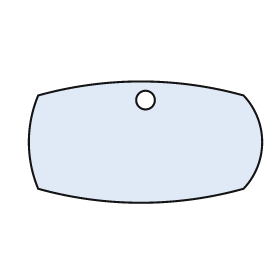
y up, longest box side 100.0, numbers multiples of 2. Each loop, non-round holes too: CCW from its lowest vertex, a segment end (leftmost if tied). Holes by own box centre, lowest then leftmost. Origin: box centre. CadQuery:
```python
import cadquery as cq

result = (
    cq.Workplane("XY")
    .moveTo(-46.0, -20.0)
    .threePointArc((-2.0, -26.0), (42.0, -20.0))
    .threePointArc((50.0, 0.0), (42.0, 20.0))
    .threePointArc((-2.0, 26.0), (-46.0, 20.0))
    .threePointArc((-50.0, 0.0), (-46.0, -20.0))
    .close()
    .moveTo(0.0, 18.0)
    .circle(4.0)
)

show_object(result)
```